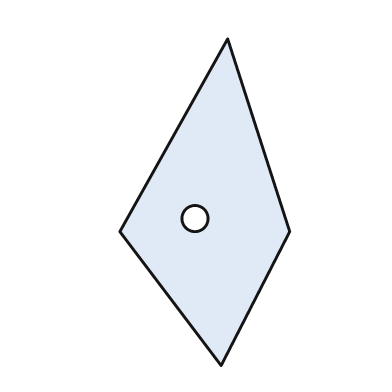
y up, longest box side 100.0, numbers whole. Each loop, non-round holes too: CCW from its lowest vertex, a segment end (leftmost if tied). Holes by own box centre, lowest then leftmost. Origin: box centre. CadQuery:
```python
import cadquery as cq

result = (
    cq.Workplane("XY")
    .moveTo(5.0, -50.0)
    .lineTo(26.0, -9.0)
    .lineTo(7.0, 50.0)
    .lineTo(-26.0, -9.0)
    .close()
    .moveTo(-3.0, -5.0)
    .circle(4.0)
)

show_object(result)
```